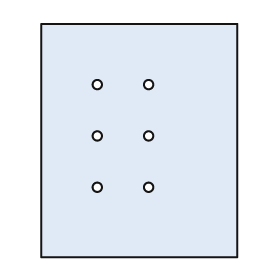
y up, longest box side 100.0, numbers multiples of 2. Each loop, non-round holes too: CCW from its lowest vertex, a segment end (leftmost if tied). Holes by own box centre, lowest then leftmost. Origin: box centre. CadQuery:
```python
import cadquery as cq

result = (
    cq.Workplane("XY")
    .moveTo(-42.0, -50.0)
    .lineTo(42.0, -50.0)
    .lineTo(42.0, 50.0)
    .lineTo(-42.0, 50.0)
    .close()
    .moveTo(-18.0, -20.0)
    .circle(2.0)
    .moveTo(4.0, -20.0)
    .circle(2.0)
    .moveTo(-18.0, 2.0)
    .circle(2.0)
    .moveTo(4.0, 2.0)
    .circle(2.0)
    .moveTo(-18.0, 24.0)
    .circle(2.0)
    .moveTo(4.0, 24.0)
    .circle(2.0)
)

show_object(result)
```